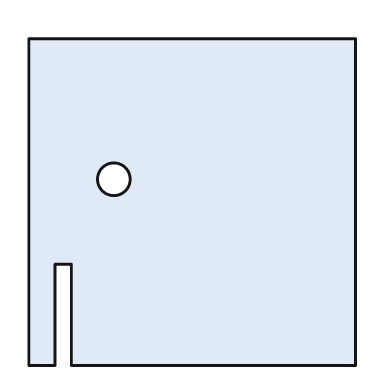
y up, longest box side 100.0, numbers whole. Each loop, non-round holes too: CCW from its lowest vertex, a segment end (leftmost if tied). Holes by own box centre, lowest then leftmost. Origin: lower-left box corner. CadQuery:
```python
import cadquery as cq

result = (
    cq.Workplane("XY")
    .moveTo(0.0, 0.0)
    .lineTo(8.0, 0.0)
    .lineTo(8.0, 31.0)
    .lineTo(13.0, 31.0)
    .lineTo(13.0, 0.0)
    .lineTo(100.0, 0.0)
    .lineTo(100.0, 100.0)
    .lineTo(0.0, 100.0)
    .close()
    .moveTo(26.0, 57.0)
    .circle(5.0)
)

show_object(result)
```